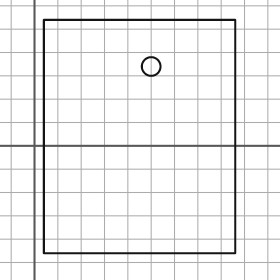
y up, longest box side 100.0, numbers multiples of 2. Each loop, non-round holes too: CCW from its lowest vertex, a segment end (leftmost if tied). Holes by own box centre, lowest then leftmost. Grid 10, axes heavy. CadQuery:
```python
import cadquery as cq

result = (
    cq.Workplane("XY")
    .moveTo(4.0, -46.0)
    .lineTo(86.0, -46.0)
    .lineTo(86.0, 54.0)
    .lineTo(4.0, 54.0)
    .close()
    .moveTo(50.0, 34.0)
    .circle(4.0)
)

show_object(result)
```